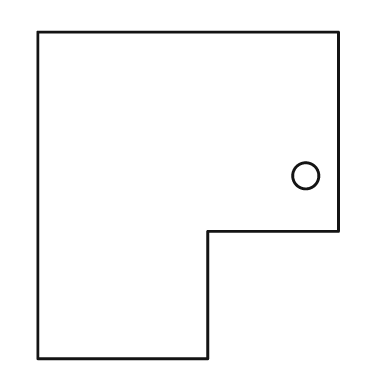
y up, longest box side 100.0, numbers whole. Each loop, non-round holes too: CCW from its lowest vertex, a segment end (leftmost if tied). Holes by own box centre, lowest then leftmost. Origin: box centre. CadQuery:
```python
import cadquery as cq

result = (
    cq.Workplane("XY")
    .moveTo(-46.0, -50.0)
    .lineTo(6.0, -50.0)
    .lineTo(6.0, -11.0)
    .lineTo(46.0, -11.0)
    .lineTo(46.0, 50.0)
    .lineTo(-46.0, 50.0)
    .close()
    .moveTo(36.0, 6.0)
    .circle(4.0)
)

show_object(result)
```